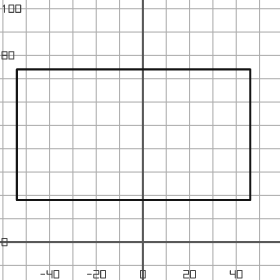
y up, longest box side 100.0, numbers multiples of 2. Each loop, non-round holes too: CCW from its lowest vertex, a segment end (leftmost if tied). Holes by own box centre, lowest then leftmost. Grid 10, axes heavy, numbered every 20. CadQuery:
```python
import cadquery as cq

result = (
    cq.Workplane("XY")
    .moveTo(-54.0, 18.0)
    .lineTo(46.0, 18.0)
    .lineTo(46.0, 74.0)
    .lineTo(-54.0, 74.0)
    .close()
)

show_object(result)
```